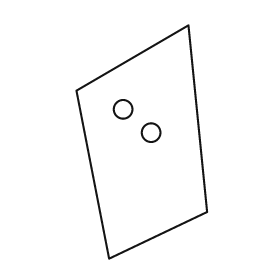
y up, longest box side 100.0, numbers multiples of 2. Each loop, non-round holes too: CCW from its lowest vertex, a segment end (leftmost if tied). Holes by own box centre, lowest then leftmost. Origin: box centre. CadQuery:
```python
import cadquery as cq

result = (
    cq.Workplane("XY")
    .moveTo(-14.0, -50.0)
    .lineTo(28.0, -30.0)
    .lineTo(20.0, 50.0)
    .lineTo(-28.0, 22.0)
    .close()
    .moveTo(4.0, 4.0)
    .circle(4.0)
    .moveTo(-8.0, 14.0)
    .circle(4.0)
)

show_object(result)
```